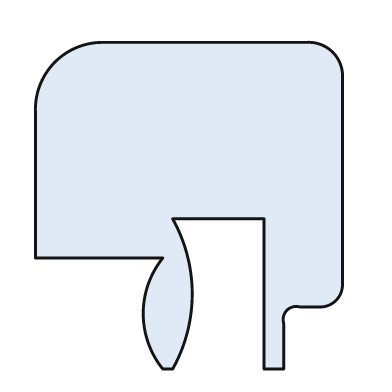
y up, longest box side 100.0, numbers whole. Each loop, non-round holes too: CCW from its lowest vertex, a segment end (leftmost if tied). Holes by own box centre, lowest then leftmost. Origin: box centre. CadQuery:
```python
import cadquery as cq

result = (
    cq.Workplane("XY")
    .moveTo(-8.0, -50.0)
    .lineTo(-5.0, -50.0)
    .threePointArc((1.0, -27.0), (-5.0, -4.0))
    .lineTo(23.0, -4.0)
    .lineTo(23.0, -50.0)
    .lineTo(29.0, -50.0)
    .lineTo(29.0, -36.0)
    .threePointArc((30.0, -32.0), (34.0, -31.0))
    .lineTo(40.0, -31.0)
    .threePointArc((45.0, -29.0), (47.0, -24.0))
    .lineTo(47.0, 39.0)
    .threePointArc((44.0, 47.0), (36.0, 50.0))
    .lineTo(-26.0, 50.0)
    .threePointArc((-41.0, 44.0), (-47.0, 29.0))
    .lineTo(-47.0, -16.0)
    .lineTo(-8.0, -16.0)
    .threePointArc((-14.0, -33.0), (-8.0, -50.0))
    .close()
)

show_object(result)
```